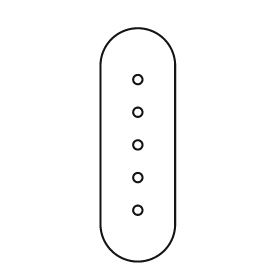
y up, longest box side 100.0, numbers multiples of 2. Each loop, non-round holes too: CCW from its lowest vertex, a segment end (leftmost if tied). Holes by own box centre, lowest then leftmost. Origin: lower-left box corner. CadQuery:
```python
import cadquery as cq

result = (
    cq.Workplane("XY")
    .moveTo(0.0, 16.0)
    .threePointArc((16.0, 0.0), (32.0, 16.0))
    .lineTo(32.0, 84.0)
    .threePointArc((16.0, 100.0), (0.0, 84.0))
    .close()
    .moveTo(16.0, 22.0)
    .circle(2.0)
    .moveTo(16.0, 36.0)
    .circle(2.0)
    .moveTo(16.0, 50.0)
    .circle(2.0)
    .moveTo(16.0, 64.0)
    .circle(2.0)
    .moveTo(16.0, 78.0)
    .circle(2.0)
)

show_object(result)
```